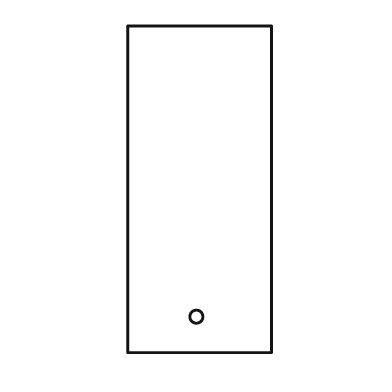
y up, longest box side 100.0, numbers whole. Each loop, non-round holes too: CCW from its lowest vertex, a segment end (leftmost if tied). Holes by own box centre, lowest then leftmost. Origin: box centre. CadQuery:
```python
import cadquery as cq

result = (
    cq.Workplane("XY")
    .moveTo(-22.0, -50.0)
    .lineTo(22.0, -50.0)
    .lineTo(22.0, 50.0)
    .lineTo(-22.0, 50.0)
    .close()
    .moveTo(-1.0, -39.0)
    .circle(2.0)
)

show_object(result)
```